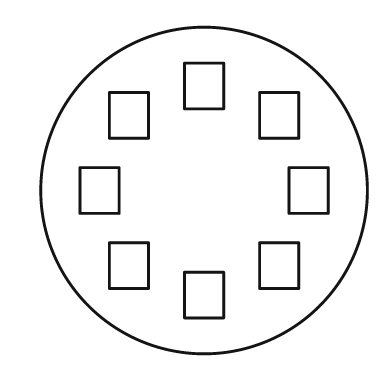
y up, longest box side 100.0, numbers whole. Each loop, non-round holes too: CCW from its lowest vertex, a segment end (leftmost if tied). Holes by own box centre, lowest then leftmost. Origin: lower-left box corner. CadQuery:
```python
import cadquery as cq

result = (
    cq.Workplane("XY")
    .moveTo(50.0, 50.0)
    .circle(50.0)
    .moveTo(44.0, 11.0)
    .lineTo(56.0, 11.0)
    .lineTo(56.0, 25.0)
    .lineTo(44.0, 25.0)
    .close()
    .moveTo(21.0, 20.0)
    .lineTo(33.0, 20.0)
    .lineTo(33.0, 34.0)
    .lineTo(21.0, 34.0)
    .close()
    .moveTo(67.0, 20.0)
    .lineTo(79.0, 20.0)
    .lineTo(79.0, 34.0)
    .lineTo(67.0, 34.0)
    .close()
    .moveTo(12.0, 43.0)
    .lineTo(24.0, 43.0)
    .lineTo(24.0, 57.0)
    .lineTo(12.0, 57.0)
    .close()
    .moveTo(76.0, 43.0)
    .lineTo(88.0, 43.0)
    .lineTo(88.0, 57.0)
    .lineTo(76.0, 57.0)
    .close()
    .moveTo(21.0, 66.0)
    .lineTo(33.0, 66.0)
    .lineTo(33.0, 80.0)
    .lineTo(21.0, 80.0)
    .close()
    .moveTo(67.0, 66.0)
    .lineTo(79.0, 66.0)
    .lineTo(79.0, 80.0)
    .lineTo(67.0, 80.0)
    .close()
    .moveTo(44.0, 75.0)
    .lineTo(56.0, 75.0)
    .lineTo(56.0, 89.0)
    .lineTo(44.0, 89.0)
    .close()
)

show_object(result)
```